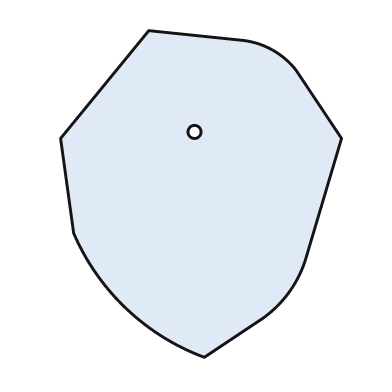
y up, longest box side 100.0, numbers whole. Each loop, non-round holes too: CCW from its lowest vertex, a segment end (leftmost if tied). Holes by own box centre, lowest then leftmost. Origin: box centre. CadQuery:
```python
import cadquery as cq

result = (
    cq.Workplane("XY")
    .moveTo(1.0, -50.0)
    .lineTo(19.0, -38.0)
    .threePointArc((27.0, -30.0), (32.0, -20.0))
    .lineTo(43.0, 17.0)
    .lineTo(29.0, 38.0)
    .threePointArc((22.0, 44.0), (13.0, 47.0))
    .lineTo(-16.0, 50.0)
    .lineTo(-43.0, 17.0)
    .lineTo(-39.0, -12.0)
    .threePointArc((-23.0, -35.0), (1.0, -50.0))
    .close()
    .moveTo(-2.0, 19.0)
    .circle(2.0)
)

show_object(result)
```